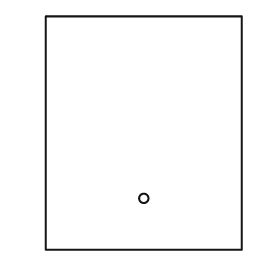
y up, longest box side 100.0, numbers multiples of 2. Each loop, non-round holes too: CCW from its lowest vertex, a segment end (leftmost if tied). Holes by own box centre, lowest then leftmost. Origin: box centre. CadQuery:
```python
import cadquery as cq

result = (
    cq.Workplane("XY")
    .moveTo(-42.0, -50.0)
    .lineTo(42.0, -50.0)
    .lineTo(42.0, 50.0)
    .lineTo(-42.0, 50.0)
    .close()
    .moveTo(0.0, -28.0)
    .circle(2.0)
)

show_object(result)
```